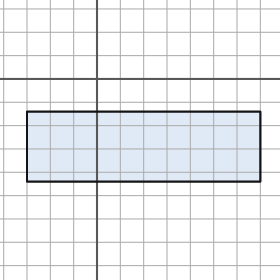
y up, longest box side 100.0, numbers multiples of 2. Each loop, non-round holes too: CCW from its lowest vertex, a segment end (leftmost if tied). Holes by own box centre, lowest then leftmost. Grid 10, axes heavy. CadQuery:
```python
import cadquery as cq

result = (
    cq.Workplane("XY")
    .moveTo(-30.0, -44.0)
    .lineTo(70.0, -44.0)
    .lineTo(70.0, -14.0)
    .lineTo(-30.0, -14.0)
    .close()
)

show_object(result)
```